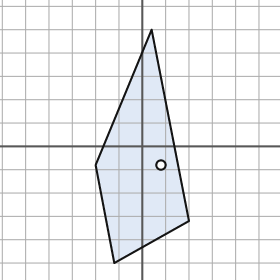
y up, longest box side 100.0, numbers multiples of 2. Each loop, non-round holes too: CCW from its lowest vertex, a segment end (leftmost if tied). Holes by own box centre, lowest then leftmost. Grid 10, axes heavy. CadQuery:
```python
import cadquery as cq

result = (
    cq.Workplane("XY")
    .moveTo(-12.0, -50.0)
    .lineTo(20.0, -32.0)
    .lineTo(4.0, 50.0)
    .lineTo(-20.0, -8.0)
    .close()
    .moveTo(8.0, -8.0)
    .circle(2.0)
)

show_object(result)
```